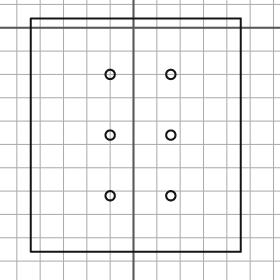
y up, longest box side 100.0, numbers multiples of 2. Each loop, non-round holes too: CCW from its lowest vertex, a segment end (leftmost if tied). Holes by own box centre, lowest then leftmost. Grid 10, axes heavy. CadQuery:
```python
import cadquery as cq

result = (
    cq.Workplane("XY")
    .moveTo(-44.0, -96.0)
    .lineTo(46.0, -96.0)
    .lineTo(46.0, 4.0)
    .lineTo(-44.0, 4.0)
    .close()
    .moveTo(-10.0, -72.0)
    .circle(2.0)
    .moveTo(16.0, -72.0)
    .circle(2.0)
    .moveTo(-10.0, -46.0)
    .circle(2.0)
    .moveTo(16.0, -46.0)
    .circle(2.0)
    .moveTo(-10.0, -20.0)
    .circle(2.0)
    .moveTo(16.0, -20.0)
    .circle(2.0)
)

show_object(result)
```